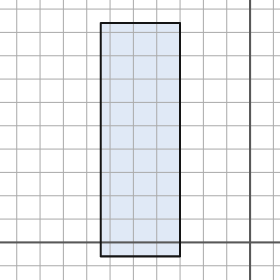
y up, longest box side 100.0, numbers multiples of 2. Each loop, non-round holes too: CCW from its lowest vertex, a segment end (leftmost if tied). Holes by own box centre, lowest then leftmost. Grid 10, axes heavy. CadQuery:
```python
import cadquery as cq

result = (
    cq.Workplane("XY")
    .moveTo(-64.0, -6.0)
    .lineTo(-30.0, -6.0)
    .lineTo(-30.0, 94.0)
    .lineTo(-64.0, 94.0)
    .close()
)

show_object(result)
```